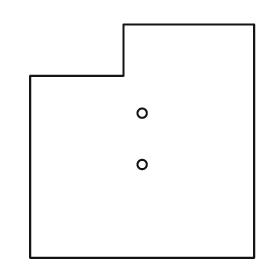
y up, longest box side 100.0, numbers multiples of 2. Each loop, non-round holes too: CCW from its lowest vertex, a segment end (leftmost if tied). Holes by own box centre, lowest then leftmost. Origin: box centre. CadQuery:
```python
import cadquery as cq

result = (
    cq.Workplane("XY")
    .moveTo(-48.0, -50.0)
    .lineTo(48.0, -50.0)
    .lineTo(48.0, 50.0)
    .lineTo(-8.0, 50.0)
    .lineTo(-8.0, 28.0)
    .lineTo(-48.0, 28.0)
    .close()
    .moveTo(0.0, -10.0)
    .circle(2.0)
    .moveTo(0.0, 12.0)
    .circle(2.0)
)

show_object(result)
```